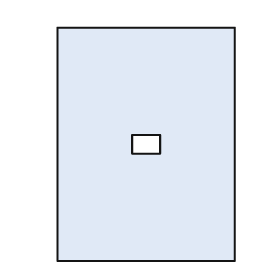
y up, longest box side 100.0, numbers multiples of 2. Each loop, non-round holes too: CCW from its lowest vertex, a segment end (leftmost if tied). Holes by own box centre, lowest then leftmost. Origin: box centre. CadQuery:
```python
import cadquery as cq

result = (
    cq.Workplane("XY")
    .moveTo(-38.0, -50.0)
    .lineTo(38.0, -50.0)
    .lineTo(38.0, 50.0)
    .lineTo(-38.0, 50.0)
    .close()
    .moveTo(-6.0, -4.0)
    .lineTo(6.0, -4.0)
    .lineTo(6.0, 4.0)
    .lineTo(-6.0, 4.0)
    .close()
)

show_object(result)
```